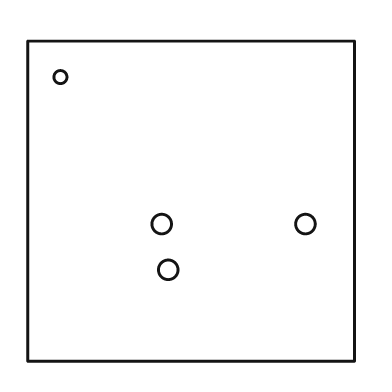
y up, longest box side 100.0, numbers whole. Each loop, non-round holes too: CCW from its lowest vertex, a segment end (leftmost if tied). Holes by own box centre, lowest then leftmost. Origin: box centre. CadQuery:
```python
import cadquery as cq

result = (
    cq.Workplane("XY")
    .moveTo(-50.0, -49.0)
    .lineTo(50.0, -49.0)
    .lineTo(50.0, 49.0)
    .lineTo(-50.0, 49.0)
    .close()
    .moveTo(-7.0, -21.0)
    .circle(3.0)
    .moveTo(-9.0, -7.0)
    .circle(3.0)
    .moveTo(35.0, -7.0)
    .circle(3.0)
    .moveTo(-40.0, 38.0)
    .circle(2.0)
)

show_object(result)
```